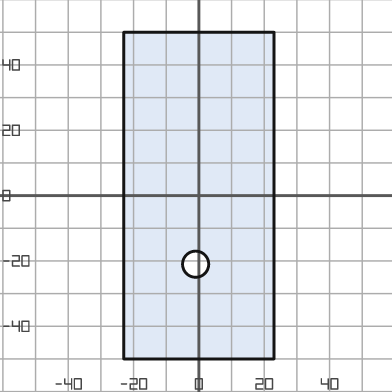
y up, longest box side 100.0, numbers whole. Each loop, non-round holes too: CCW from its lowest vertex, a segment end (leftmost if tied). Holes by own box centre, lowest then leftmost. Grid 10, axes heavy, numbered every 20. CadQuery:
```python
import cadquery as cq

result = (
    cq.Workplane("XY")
    .moveTo(-23.0, -50.0)
    .lineTo(23.0, -50.0)
    .lineTo(23.0, 50.0)
    .lineTo(-23.0, 50.0)
    .close()
    .moveTo(-1.0, -21.0)
    .circle(4.0)
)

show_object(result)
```